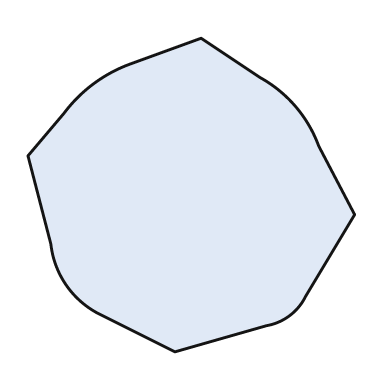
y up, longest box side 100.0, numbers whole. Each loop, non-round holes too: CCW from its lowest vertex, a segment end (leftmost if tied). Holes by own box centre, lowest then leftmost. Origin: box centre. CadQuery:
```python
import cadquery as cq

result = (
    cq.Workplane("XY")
    .moveTo(-5.0, -48.0)
    .lineTo(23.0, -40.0)
    .threePointArc((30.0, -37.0), (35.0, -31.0))
    .lineTo(50.0, -6.0)
    .lineTo(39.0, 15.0)
    .threePointArc((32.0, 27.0), (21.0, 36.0))
    .lineTo(3.0, 48.0)
    .lineTo(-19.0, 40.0)
    .threePointArc((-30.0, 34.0), (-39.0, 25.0))
    .lineTo(-50.0, 12.0)
    .lineTo(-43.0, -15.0)
    .threePointArc((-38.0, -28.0), (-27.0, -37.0))
    .close()
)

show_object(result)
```